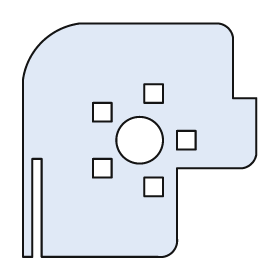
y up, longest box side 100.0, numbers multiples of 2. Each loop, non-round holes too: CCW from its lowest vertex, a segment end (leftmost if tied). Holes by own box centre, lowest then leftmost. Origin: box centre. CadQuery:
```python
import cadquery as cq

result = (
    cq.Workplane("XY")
    .moveTo(-50.0, -50.0)
    .lineTo(-46.0, -50.0)
    .lineTo(-46.0, -8.0)
    .lineTo(-42.0, -8.0)
    .lineTo(-42.0, -50.0)
    .lineTo(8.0, -50.0)
    .threePointArc((14.0, -48.0), (16.0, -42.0))
    .lineTo(16.0, -12.0)
    .lineTo(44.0, -12.0)
    .threePointArc((48.0, -10.0), (50.0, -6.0))
    .lineTo(50.0, 18.0)
    .lineTo(40.0, 18.0)
    .lineTo(40.0, 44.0)
    .threePointArc((38.0, 48.0), (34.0, 50.0))
    .lineTo(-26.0, 50.0)
    .threePointArc((-42.0, 42.0), (-50.0, 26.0))
    .close()
    .moveTo(2.0, -24.0)
    .lineTo(10.0, -24.0)
    .lineTo(10.0, -16.0)
    .lineTo(2.0, -16.0)
    .close()
    .moveTo(-20.0, -16.0)
    .lineTo(-12.0, -16.0)
    .lineTo(-12.0, -8.0)
    .lineTo(-20.0, -8.0)
    .close()
    .moveTo(0.0, 0.0)
    .circle(10.0)
    .moveTo(16.0, -4.0)
    .lineTo(24.0, -4.0)
    .lineTo(24.0, 4.0)
    .lineTo(16.0, 4.0)
    .close()
    .moveTo(-20.0, 8.0)
    .lineTo(-12.0, 8.0)
    .lineTo(-12.0, 16.0)
    .lineTo(-20.0, 16.0)
    .close()
    .moveTo(2.0, 16.0)
    .lineTo(10.0, 16.0)
    .lineTo(10.0, 24.0)
    .lineTo(2.0, 24.0)
    .close()
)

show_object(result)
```